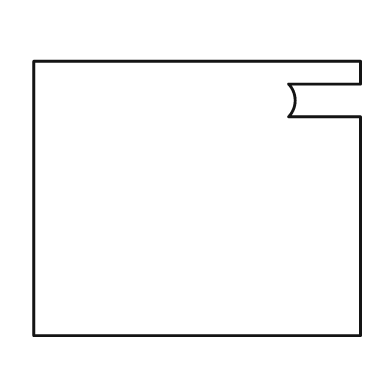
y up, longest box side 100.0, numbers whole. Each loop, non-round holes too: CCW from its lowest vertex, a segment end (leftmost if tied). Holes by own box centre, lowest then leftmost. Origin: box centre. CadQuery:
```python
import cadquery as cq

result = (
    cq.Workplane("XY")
    .moveTo(-50.0, -42.0)
    .lineTo(50.0, -42.0)
    .lineTo(50.0, 25.0)
    .lineTo(28.0, 25.0)
    .threePointArc((30.0, 30.0), (28.0, 35.0))
    .lineTo(50.0, 35.0)
    .lineTo(50.0, 42.0)
    .lineTo(-50.0, 42.0)
    .close()
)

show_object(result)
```